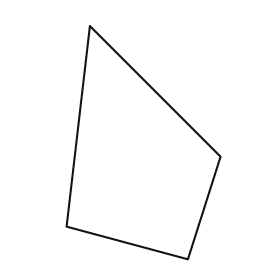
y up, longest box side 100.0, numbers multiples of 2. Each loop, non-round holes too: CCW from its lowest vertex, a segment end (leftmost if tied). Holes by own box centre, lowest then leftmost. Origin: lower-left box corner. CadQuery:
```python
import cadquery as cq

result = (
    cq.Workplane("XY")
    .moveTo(52.0, 0.0)
    .lineTo(66.0, 44.0)
    .lineTo(10.0, 100.0)
    .lineTo(0.0, 14.0)
    .close()
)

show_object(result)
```